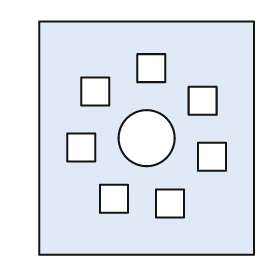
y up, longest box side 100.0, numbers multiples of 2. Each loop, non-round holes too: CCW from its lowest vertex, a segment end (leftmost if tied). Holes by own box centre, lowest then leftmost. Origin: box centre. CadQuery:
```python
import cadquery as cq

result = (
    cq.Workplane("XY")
    .moveTo(-46.0, -50.0)
    .lineTo(46.0, -50.0)
    .lineTo(46.0, 50.0)
    .lineTo(-46.0, 50.0)
    .close()
    .moveTo(4.0, -34.0)
    .lineTo(16.0, -34.0)
    .lineTo(16.0, -22.0)
    .lineTo(4.0, -22.0)
    .close()
    .moveTo(-20.0, -32.0)
    .lineTo(-8.0, -32.0)
    .lineTo(-8.0, -20.0)
    .lineTo(-20.0, -20.0)
    .close()
    .moveTo(22.0, -14.0)
    .lineTo(34.0, -14.0)
    .lineTo(34.0, -2.0)
    .lineTo(22.0, -2.0)
    .close()
    .moveTo(-34.0, -10.0)
    .lineTo(-22.0, -10.0)
    .lineTo(-22.0, 2.0)
    .lineTo(-34.0, 2.0)
    .close()
    .moveTo(0.0, 0.0)
    .circle(12.0)
    .moveTo(18.0, 10.0)
    .lineTo(30.0, 10.0)
    .lineTo(30.0, 22.0)
    .lineTo(18.0, 22.0)
    .close()
    .moveTo(-28.0, 14.0)
    .lineTo(-16.0, 14.0)
    .lineTo(-16.0, 26.0)
    .lineTo(-28.0, 26.0)
    .close()
    .moveTo(-4.0, 24.0)
    .lineTo(8.0, 24.0)
    .lineTo(8.0, 36.0)
    .lineTo(-4.0, 36.0)
    .close()
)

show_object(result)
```